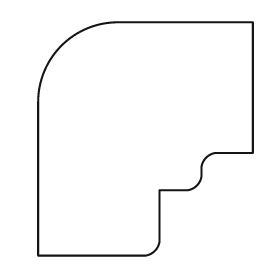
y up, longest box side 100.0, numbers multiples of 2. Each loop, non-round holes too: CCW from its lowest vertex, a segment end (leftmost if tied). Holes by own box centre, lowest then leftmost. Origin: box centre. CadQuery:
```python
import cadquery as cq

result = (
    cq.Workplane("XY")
    .moveTo(-46.0, -50.0)
    .lineTo(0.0, -50.0)
    .threePointArc((4.0, -48.0), (6.0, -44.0))
    .lineTo(6.0, -22.0)
    .lineTo(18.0, -22.0)
    .threePointArc((22.0, -20.0), (24.0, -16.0))
    .lineTo(24.0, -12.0)
    .threePointArc((26.0, -8.0), (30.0, -6.0))
    .lineTo(46.0, -6.0)
    .lineTo(46.0, 50.0)
    .lineTo(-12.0, 50.0)
    .threePointArc((-36.0, 40.0), (-46.0, 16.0))
    .close()
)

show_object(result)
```